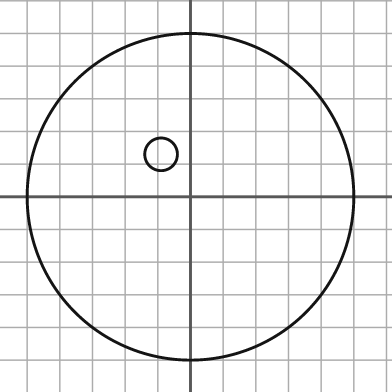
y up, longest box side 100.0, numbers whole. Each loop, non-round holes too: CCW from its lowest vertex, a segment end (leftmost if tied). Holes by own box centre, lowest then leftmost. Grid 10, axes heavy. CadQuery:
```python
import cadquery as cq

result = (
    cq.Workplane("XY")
    .moveTo(0.0, 0.0)
    .circle(50.0)
    .moveTo(-9.0, 13.0)
    .circle(5.0)
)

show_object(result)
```